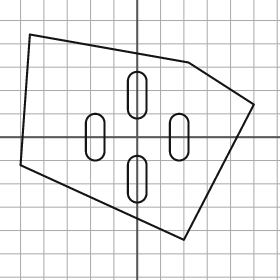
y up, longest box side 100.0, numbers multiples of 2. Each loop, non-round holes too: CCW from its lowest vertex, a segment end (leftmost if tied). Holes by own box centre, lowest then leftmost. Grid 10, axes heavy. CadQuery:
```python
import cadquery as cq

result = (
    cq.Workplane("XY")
    .moveTo(20.0, -44.0)
    .lineTo(50.0, 14.0)
    .lineTo(22.0, 32.0)
    .lineTo(-46.0, 44.0)
    .lineTo(-50.0, -12.0)
    .close()
    .moveTo(-4.0, -24.0)
    .threePointArc((0.0, -28.0), (4.0, -24.0))
    .lineTo(4.0, -12.0)
    .threePointArc((0.0, -8.0), (-4.0, -12.0))
    .close()
    .moveTo(-22.0, -6.0)
    .threePointArc((-18.0, -10.0), (-14.0, -6.0))
    .lineTo(-14.0, 6.0)
    .threePointArc((-18.0, 10.0), (-22.0, 6.0))
    .close()
    .moveTo(14.0, -6.0)
    .threePointArc((18.0, -10.0), (22.0, -6.0))
    .lineTo(22.0, 6.0)
    .threePointArc((18.0, 10.0), (14.0, 6.0))
    .close()
    .moveTo(-4.0, 12.0)
    .threePointArc((0.0, 8.0), (4.0, 12.0))
    .lineTo(4.0, 24.0)
    .threePointArc((0.0, 28.0), (-4.0, 24.0))
    .close()
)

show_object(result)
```